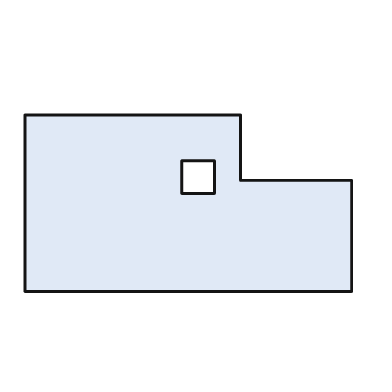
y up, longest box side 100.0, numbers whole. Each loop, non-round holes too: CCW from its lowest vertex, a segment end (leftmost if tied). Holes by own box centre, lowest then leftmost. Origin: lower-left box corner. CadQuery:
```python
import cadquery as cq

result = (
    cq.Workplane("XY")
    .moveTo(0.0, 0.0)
    .lineTo(100.0, 0.0)
    .lineTo(100.0, 34.0)
    .lineTo(66.0, 34.0)
    .lineTo(66.0, 54.0)
    .lineTo(0.0, 54.0)
    .close()
    .moveTo(48.0, 30.0)
    .lineTo(58.0, 30.0)
    .lineTo(58.0, 40.0)
    .lineTo(48.0, 40.0)
    .close()
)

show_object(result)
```